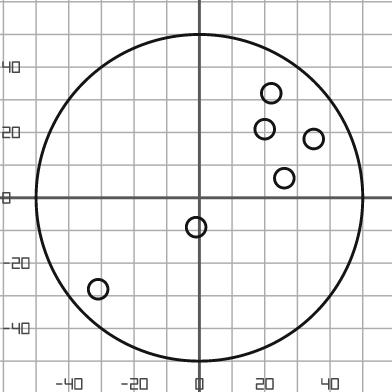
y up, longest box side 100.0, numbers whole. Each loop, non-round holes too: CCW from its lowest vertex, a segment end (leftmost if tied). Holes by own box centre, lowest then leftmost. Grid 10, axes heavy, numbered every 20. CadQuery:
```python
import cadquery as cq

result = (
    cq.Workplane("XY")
    .moveTo(0.0, 0.0)
    .circle(50.0)
    .moveTo(-31.0, -28.0)
    .circle(3.0)
    .moveTo(-1.0, -9.0)
    .circle(3.0)
    .moveTo(26.0, 6.0)
    .circle(3.0)
    .moveTo(35.0, 18.0)
    .circle(3.0)
    .moveTo(20.0, 21.0)
    .circle(3.0)
    .moveTo(22.0, 32.0)
    .circle(3.0)
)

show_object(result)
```